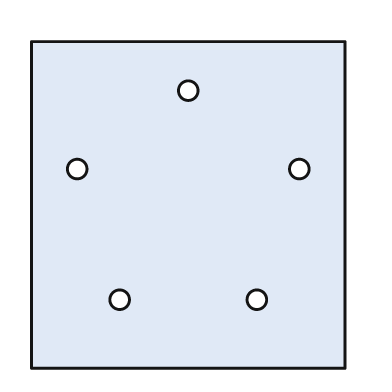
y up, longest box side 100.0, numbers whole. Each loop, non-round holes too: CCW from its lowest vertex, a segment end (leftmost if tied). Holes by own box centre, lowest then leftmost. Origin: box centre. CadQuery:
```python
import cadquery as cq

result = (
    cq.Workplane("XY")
    .moveTo(-48.0, -50.0)
    .lineTo(48.0, -50.0)
    .lineTo(48.0, 50.0)
    .lineTo(-48.0, 50.0)
    .close()
    .moveTo(-21.0, -29.0)
    .circle(3.0)
    .moveTo(21.0, -29.0)
    .circle(3.0)
    .moveTo(-34.0, 11.0)
    .circle(3.0)
    .moveTo(34.0, 11.0)
    .circle(3.0)
    .moveTo(0.0, 35.0)
    .circle(3.0)
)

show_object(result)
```